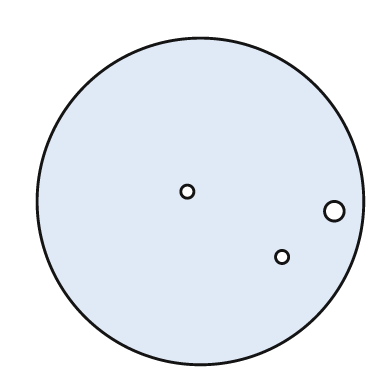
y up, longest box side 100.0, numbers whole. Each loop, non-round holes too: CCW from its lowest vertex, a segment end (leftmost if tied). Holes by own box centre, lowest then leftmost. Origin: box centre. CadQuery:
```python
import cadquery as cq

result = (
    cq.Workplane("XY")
    .moveTo(0.0, 0.0)
    .circle(50.0)
    .moveTo(25.0, -17.0)
    .circle(2.0)
    .moveTo(41.0, -3.0)
    .circle(3.0)
    .moveTo(-4.0, 3.0)
    .circle(2.0)
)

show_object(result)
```